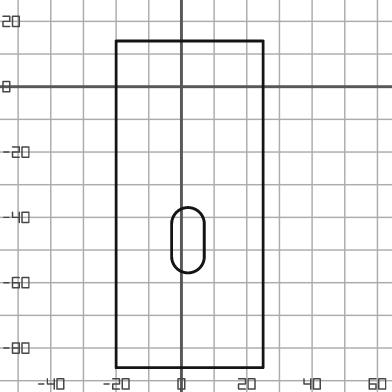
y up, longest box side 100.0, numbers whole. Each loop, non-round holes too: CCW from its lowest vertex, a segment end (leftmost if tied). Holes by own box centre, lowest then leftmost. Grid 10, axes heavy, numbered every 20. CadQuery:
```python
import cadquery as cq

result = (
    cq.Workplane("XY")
    .moveTo(-20.0, -86.0)
    .lineTo(25.0, -86.0)
    .lineTo(25.0, 14.0)
    .lineTo(-20.0, 14.0)
    .close()
    .moveTo(-3.0, -52.0)
    .threePointArc((2.0, -57.0), (7.0, -52.0))
    .lineTo(7.0, -42.0)
    .threePointArc((2.0, -37.0), (-3.0, -42.0))
    .close()
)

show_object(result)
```